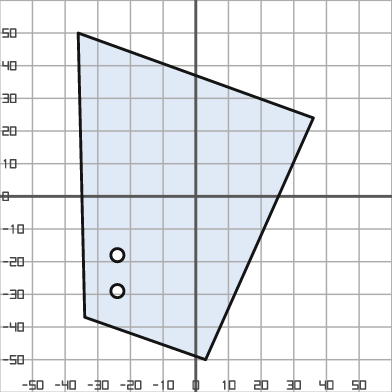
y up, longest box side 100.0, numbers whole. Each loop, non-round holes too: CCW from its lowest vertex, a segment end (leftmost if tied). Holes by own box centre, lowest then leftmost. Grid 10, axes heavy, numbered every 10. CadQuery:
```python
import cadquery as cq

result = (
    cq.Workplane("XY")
    .moveTo(3.0, -50.0)
    .lineTo(36.0, 24.0)
    .lineTo(-36.0, 50.0)
    .lineTo(-34.0, -37.0)
    .close()
    .moveTo(-24.0, -29.0)
    .circle(2.0)
    .moveTo(-24.0, -18.0)
    .circle(2.0)
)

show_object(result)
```